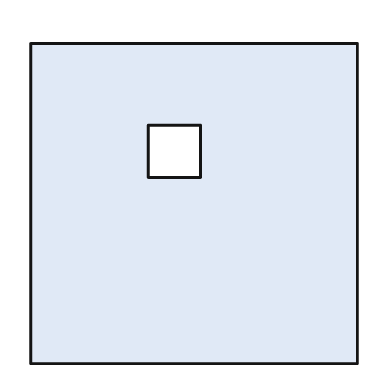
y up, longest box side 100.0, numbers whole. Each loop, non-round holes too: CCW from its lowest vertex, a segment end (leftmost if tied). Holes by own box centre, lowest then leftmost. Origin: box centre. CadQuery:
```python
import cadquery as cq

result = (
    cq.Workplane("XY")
    .moveTo(-50.0, -49.0)
    .lineTo(50.0, -49.0)
    .lineTo(50.0, 49.0)
    .lineTo(-50.0, 49.0)
    .close()
    .moveTo(-14.0, 8.0)
    .lineTo(2.0, 8.0)
    .lineTo(2.0, 24.0)
    .lineTo(-14.0, 24.0)
    .close()
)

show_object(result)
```